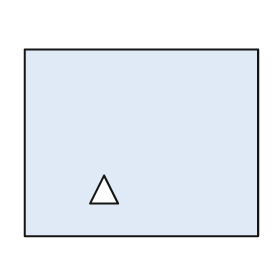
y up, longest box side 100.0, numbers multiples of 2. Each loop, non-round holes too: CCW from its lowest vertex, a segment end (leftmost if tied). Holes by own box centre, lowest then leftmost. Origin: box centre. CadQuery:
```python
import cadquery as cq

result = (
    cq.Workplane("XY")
    .moveTo(-50.0, -40.0)
    .lineTo(50.0, -40.0)
    .lineTo(50.0, 40.0)
    .lineTo(-50.0, 40.0)
    .close()
    .moveTo(-22.0, -26.0)
    .lineTo(-10.0, -26.0)
    .lineTo(-16.0, -14.0)
    .close()
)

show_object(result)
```